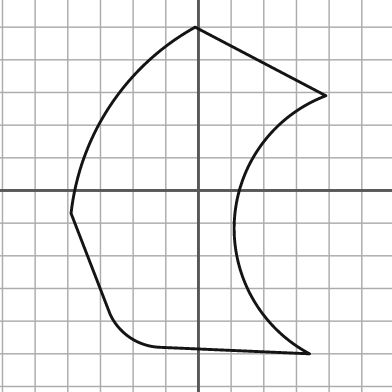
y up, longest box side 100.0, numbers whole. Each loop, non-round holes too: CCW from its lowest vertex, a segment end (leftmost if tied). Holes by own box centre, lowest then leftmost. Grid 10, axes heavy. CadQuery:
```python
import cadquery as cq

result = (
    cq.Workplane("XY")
    .moveTo(34.0, -50.0)
    .threePointArc((11.0, -9.0), (39.0, 29.0))
    .lineTo(-1.0, 50.0)
    .threePointArc((-27.0, 26.0), (-39.0, -7.0))
    .lineTo(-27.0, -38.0)
    .threePointArc((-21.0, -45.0), (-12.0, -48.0))
    .close()
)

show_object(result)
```